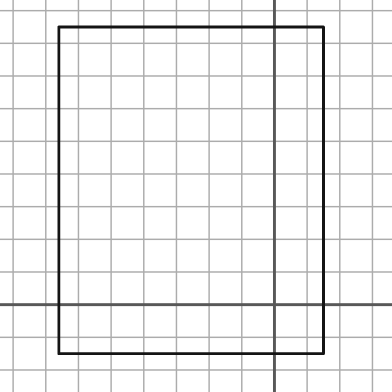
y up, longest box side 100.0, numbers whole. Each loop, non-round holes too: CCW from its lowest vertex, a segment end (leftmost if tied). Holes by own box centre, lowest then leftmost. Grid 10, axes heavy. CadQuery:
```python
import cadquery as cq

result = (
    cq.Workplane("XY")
    .moveTo(-66.0, -15.0)
    .lineTo(15.0, -15.0)
    .lineTo(15.0, 85.0)
    .lineTo(-66.0, 85.0)
    .close()
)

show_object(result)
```